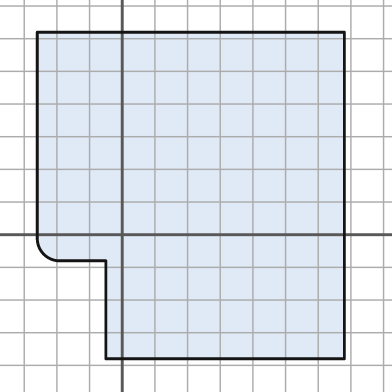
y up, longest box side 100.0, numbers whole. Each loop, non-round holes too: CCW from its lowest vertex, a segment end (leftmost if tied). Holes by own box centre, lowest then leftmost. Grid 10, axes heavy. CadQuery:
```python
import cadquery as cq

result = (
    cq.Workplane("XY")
    .moveTo(-5.0, -38.0)
    .lineTo(68.0, -38.0)
    .lineTo(68.0, 62.0)
    .lineTo(-26.0, 62.0)
    .lineTo(-26.0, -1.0)
    .threePointArc((-24.0, -6.0), (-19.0, -8.0))
    .lineTo(-5.0, -8.0)
    .close()
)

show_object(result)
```